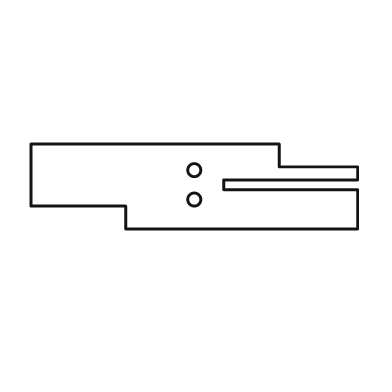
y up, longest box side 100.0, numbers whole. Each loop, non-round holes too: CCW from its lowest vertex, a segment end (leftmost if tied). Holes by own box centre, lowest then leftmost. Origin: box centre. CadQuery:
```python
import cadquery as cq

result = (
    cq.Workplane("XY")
    .moveTo(-21.0, -13.0)
    .lineTo(50.0, -13.0)
    .lineTo(50.0, -1.0)
    .lineTo(9.0, -1.0)
    .lineTo(9.0, 2.0)
    .lineTo(50.0, 2.0)
    .lineTo(50.0, 6.0)
    .lineTo(26.0, 6.0)
    .lineTo(26.0, 13.0)
    .lineTo(-50.0, 13.0)
    .lineTo(-50.0, -6.0)
    .lineTo(-21.0, -6.0)
    .close()
    .moveTo(0.0, -4.0)
    .circle(2.0)
    .moveTo(0.0, 5.0)
    .circle(2.0)
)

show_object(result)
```